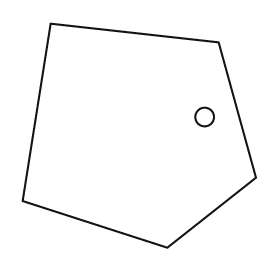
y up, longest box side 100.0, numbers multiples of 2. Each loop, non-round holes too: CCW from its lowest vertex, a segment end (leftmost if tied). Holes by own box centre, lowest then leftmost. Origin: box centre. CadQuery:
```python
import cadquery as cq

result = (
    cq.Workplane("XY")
    .moveTo(12.0, -48.0)
    .lineTo(50.0, -18.0)
    .lineTo(34.0, 40.0)
    .lineTo(-38.0, 48.0)
    .lineTo(-50.0, -28.0)
    .close()
    .moveTo(28.0, 8.0)
    .circle(4.0)
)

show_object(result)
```